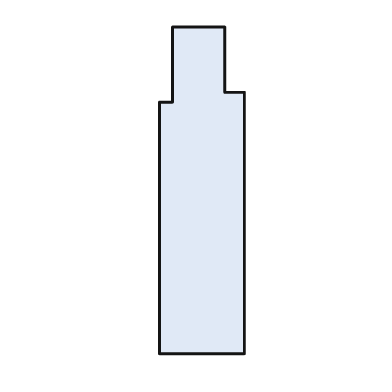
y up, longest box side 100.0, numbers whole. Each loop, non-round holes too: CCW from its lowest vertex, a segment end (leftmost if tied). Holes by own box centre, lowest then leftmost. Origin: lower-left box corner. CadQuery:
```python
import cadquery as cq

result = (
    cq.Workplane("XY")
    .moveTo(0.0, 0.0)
    .lineTo(26.0, 0.0)
    .lineTo(26.0, 80.0)
    .lineTo(20.0, 80.0)
    .lineTo(20.0, 100.0)
    .lineTo(4.0, 100.0)
    .lineTo(4.0, 77.0)
    .lineTo(0.0, 77.0)
    .close()
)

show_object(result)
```